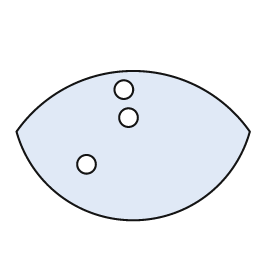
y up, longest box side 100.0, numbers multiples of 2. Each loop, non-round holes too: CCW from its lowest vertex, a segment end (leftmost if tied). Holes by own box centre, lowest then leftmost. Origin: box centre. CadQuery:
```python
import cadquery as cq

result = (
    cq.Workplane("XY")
    .moveTo(-50.0, 6.0)
    .threePointArc((0.0, -32.0), (50.0, 6.0))
    .threePointArc((0.0, 32.0), (-50.0, 6.0))
    .close()
    .moveTo(-20.0, -8.0)
    .circle(4.0)
    .moveTo(-2.0, 12.0)
    .circle(4.0)
    .moveTo(-4.0, 24.0)
    .circle(4.0)
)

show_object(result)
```